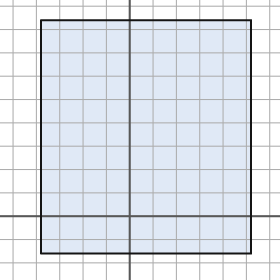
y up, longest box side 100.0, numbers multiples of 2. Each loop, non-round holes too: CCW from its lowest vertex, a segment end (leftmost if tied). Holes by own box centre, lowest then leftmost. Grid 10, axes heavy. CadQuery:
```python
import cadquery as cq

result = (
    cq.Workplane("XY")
    .moveTo(-38.0, -16.0)
    .lineTo(52.0, -16.0)
    .lineTo(52.0, 84.0)
    .lineTo(-38.0, 84.0)
    .close()
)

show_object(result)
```